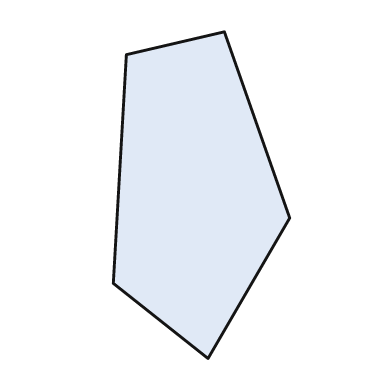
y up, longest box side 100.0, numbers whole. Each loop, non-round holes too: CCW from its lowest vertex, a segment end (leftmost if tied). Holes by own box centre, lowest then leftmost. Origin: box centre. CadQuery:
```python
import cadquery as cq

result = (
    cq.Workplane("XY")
    .moveTo(2.0, -50.0)
    .lineTo(27.0, -7.0)
    .lineTo(7.0, 50.0)
    .lineTo(-23.0, 43.0)
    .lineTo(-27.0, -27.0)
    .close()
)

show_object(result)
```